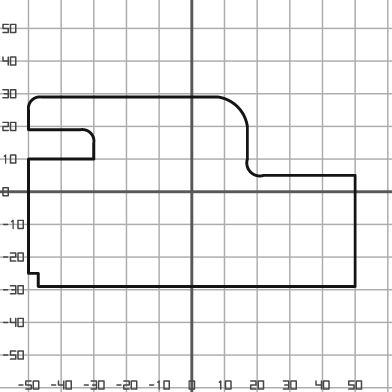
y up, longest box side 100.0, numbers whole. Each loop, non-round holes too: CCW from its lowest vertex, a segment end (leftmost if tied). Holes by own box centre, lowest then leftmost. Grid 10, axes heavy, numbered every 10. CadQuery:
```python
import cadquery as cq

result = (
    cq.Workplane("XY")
    .moveTo(-47.0, -29.0)
    .lineTo(50.0, -29.0)
    .lineTo(50.0, 5.0)
    .lineTo(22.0, 5.0)
    .threePointArc((18.0, 6.0), (17.0, 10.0))
    .lineTo(17.0, 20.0)
    .threePointArc((14.0, 26.0), (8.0, 29.0))
    .lineTo(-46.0, 29.0)
    .threePointArc((-49.0, 28.0), (-50.0, 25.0))
    .lineTo(-50.0, 19.0)
    .lineTo(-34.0, 19.0)
    .threePointArc((-31.0, 18.0), (-30.0, 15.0))
    .lineTo(-30.0, 10.0)
    .lineTo(-50.0, 10.0)
    .lineTo(-50.0, -25.0)
    .lineTo(-47.0, -25.0)
    .close()
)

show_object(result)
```